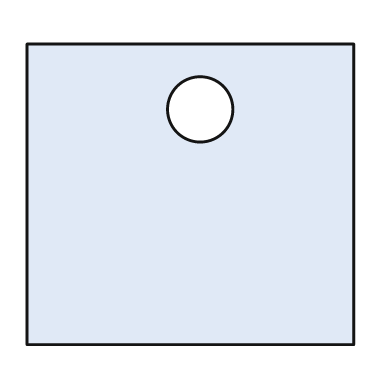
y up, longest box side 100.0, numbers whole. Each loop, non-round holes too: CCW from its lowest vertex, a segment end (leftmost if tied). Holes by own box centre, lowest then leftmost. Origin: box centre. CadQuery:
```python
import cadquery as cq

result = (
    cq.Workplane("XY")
    .moveTo(-50.0, -46.0)
    .lineTo(50.0, -46.0)
    .lineTo(50.0, 46.0)
    .lineTo(-50.0, 46.0)
    .close()
    .moveTo(3.0, 26.0)
    .circle(10.0)
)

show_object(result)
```